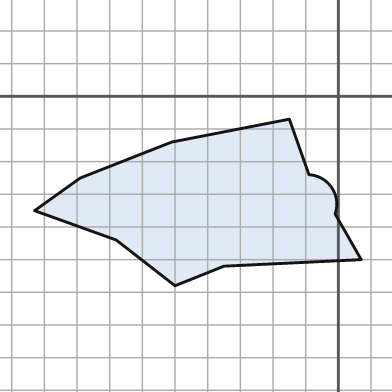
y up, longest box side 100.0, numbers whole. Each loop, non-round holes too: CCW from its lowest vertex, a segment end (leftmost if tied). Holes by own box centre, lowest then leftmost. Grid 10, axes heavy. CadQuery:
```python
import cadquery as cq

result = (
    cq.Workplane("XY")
    .moveTo(-50.0, -58.0)
    .lineTo(-35.0, -52.0)
    .lineTo(7.0, -50.0)
    .lineTo(-1.0, -36.0)
    .threePointArc((-2.0, -28.0), (-9.0, -24.0))
    .lineTo(-15.0, -7.0)
    .lineTo(-51.0, -14.0)
    .lineTo(-79.0, -25.0)
    .lineTo(-93.0, -35.0)
    .lineTo(-68.0, -44.0)
    .close()
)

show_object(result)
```